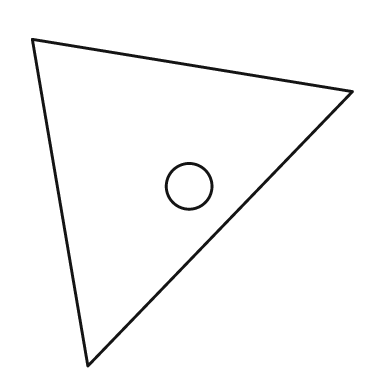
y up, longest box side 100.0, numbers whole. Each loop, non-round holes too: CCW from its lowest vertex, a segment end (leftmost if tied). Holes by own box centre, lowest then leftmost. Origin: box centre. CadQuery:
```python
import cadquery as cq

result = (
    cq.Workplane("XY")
    .moveTo(-32.0, -50.0)
    .lineTo(49.0, 34.0)
    .lineTo(-49.0, 50.0)
    .close()
    .moveTo(-1.0, 5.0)
    .circle(7.0)
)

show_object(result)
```